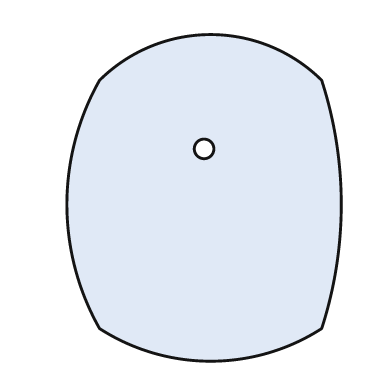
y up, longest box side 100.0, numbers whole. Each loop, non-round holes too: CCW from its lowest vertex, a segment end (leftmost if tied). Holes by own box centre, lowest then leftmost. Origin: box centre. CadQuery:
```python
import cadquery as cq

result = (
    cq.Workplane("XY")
    .moveTo(-32.0, -40.0)
    .threePointArc((2.0, -50.0), (36.0, -40.0))
    .threePointArc((42.0, -2.0), (36.0, 36.0))
    .threePointArc((2.0, 50.0), (-32.0, 36.0))
    .threePointArc((-42.0, -2.0), (-32.0, -40.0))
    .close()
    .moveTo(0.0, 15.0)
    .circle(3.0)
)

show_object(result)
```